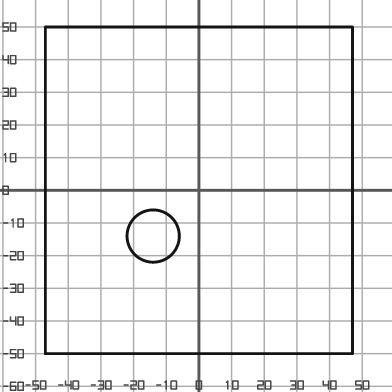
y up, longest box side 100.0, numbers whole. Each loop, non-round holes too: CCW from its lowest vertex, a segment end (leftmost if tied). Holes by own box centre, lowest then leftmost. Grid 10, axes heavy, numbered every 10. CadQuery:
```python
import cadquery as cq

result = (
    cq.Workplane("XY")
    .moveTo(-47.0, -50.0)
    .lineTo(47.0, -50.0)
    .lineTo(47.0, 50.0)
    .lineTo(-47.0, 50.0)
    .close()
    .moveTo(-14.0, -14.0)
    .circle(8.0)
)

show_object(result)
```